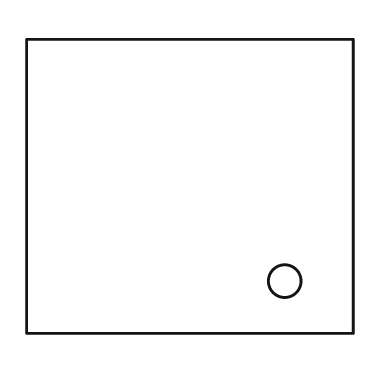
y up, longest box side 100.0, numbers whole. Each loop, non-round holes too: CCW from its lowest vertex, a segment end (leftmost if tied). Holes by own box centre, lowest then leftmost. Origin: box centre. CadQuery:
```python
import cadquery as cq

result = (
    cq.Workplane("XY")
    .moveTo(-50.0, -45.0)
    .lineTo(50.0, -45.0)
    .lineTo(50.0, 45.0)
    .lineTo(-50.0, 45.0)
    .close()
    .moveTo(29.0, -29.0)
    .circle(5.0)
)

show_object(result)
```